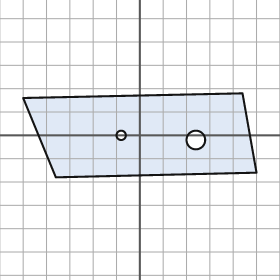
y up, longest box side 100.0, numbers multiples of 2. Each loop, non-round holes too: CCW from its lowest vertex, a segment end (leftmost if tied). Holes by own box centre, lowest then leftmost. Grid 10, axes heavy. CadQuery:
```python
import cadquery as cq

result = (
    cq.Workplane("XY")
    .moveTo(-36.0, -18.0)
    .lineTo(50.0, -16.0)
    .lineTo(44.0, 18.0)
    .lineTo(-50.0, 16.0)
    .close()
    .moveTo(24.0, -2.0)
    .circle(4.0)
    .moveTo(-8.0, 0.0)
    .circle(2.0)
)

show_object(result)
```